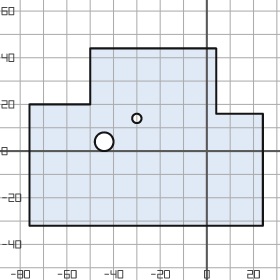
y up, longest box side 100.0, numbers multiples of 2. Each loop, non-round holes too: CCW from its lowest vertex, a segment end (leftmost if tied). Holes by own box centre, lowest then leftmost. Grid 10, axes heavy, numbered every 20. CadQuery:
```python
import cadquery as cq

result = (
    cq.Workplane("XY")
    .moveTo(-76.0, -32.0)
    .lineTo(24.0, -32.0)
    .lineTo(24.0, 16.0)
    .lineTo(4.0, 16.0)
    .lineTo(4.0, 44.0)
    .lineTo(-50.0, 44.0)
    .lineTo(-50.0, 20.0)
    .lineTo(-76.0, 20.0)
    .close()
    .moveTo(-44.0, 4.0)
    .circle(4.0)
    .moveTo(-30.0, 14.0)
    .circle(2.0)
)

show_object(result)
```